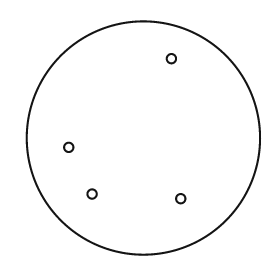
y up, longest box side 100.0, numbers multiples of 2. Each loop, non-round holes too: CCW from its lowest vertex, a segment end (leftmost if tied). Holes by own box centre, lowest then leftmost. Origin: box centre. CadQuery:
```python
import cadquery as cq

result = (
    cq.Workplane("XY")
    .moveTo(0.0, 0.0)
    .circle(50.0)
    .moveTo(16.0, -26.0)
    .circle(2.0)
    .moveTo(-22.0, -24.0)
    .circle(2.0)
    .moveTo(-32.0, -4.0)
    .circle(2.0)
    .moveTo(12.0, 34.0)
    .circle(2.0)
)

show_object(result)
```